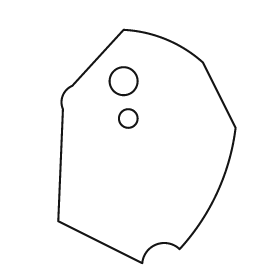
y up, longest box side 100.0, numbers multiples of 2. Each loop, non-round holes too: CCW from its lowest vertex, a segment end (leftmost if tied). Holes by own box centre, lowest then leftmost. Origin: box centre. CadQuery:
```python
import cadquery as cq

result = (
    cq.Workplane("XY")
    .moveTo(-2.0, -50.0)
    .threePointArc((4.0, -42.0), (14.0, -44.0))
    .threePointArc((30.0, -20.0), (38.0, 8.0))
    .lineTo(24.0, 36.0)
    .threePointArc((8.0, 46.0), (-10.0, 50.0))
    .lineTo(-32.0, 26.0)
    .threePointArc((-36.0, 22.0), (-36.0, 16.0))
    .lineTo(-38.0, -32.0)
    .close()
    .moveTo(-8.0, 12.0)
    .circle(4.0)
    .moveTo(-10.0, 28.0)
    .circle(6.0)
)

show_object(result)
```